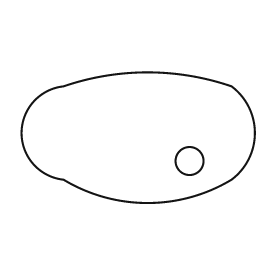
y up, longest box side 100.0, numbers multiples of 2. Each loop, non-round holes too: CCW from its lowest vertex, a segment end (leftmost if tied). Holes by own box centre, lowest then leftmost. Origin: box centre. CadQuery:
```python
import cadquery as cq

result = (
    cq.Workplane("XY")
    .moveTo(-32.0, -18.0)
    .threePointArc((4.0, -28.0), (40.0, -18.0))
    .threePointArc((50.0, 2.0), (40.0, 22.0))
    .threePointArc((4.0, 28.0), (-32.0, 22.0))
    .threePointArc((-50.0, 2.0), (-32.0, -18.0))
    .close()
    .moveTo(22.0, -10.0)
    .circle(6.0)
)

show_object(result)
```